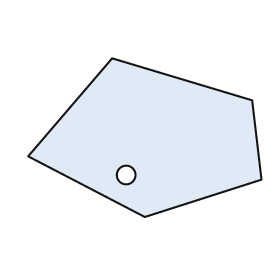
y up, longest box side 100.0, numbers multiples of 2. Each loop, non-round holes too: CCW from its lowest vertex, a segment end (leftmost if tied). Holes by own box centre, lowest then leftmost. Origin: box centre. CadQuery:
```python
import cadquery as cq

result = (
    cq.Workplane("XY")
    .moveTo(0.0, -34.0)
    .lineTo(50.0, -18.0)
    .lineTo(46.0, 16.0)
    .lineTo(-14.0, 34.0)
    .lineTo(-50.0, -8.0)
    .close()
    .moveTo(-8.0, -16.0)
    .circle(4.0)
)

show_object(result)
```